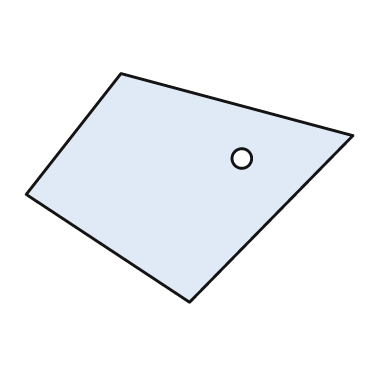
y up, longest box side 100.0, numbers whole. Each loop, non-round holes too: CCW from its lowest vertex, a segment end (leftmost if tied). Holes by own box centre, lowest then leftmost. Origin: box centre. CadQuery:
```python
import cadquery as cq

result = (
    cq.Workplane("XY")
    .moveTo(0.0, -35.0)
    .lineTo(50.0, 16.0)
    .lineTo(-21.0, 35.0)
    .lineTo(-50.0, -2.0)
    .close()
    .moveTo(16.0, 9.0)
    .circle(3.0)
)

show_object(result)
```